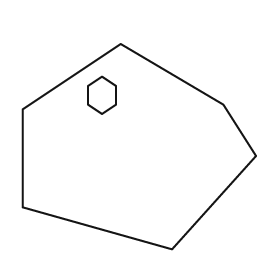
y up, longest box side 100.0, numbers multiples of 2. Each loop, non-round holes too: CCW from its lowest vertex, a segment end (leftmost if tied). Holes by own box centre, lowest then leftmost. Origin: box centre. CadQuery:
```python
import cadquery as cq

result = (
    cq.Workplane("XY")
    .moveTo(14.0, -44.0)
    .lineTo(50.0, -4.0)
    .lineTo(36.0, 18.0)
    .lineTo(-8.0, 44.0)
    .lineTo(-50.0, 16.0)
    .lineTo(-50.0, -26.0)
    .close()
    .moveTo(-16.0, 14.0)
    .lineTo(-10.0, 18.0)
    .lineTo(-10.0, 26.0)
    .lineTo(-16.0, 30.0)
    .lineTo(-22.0, 26.0)
    .lineTo(-22.0, 18.0)
    .close()
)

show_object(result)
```